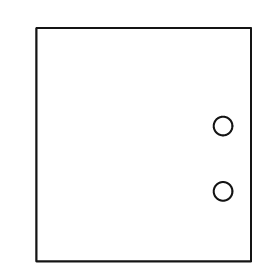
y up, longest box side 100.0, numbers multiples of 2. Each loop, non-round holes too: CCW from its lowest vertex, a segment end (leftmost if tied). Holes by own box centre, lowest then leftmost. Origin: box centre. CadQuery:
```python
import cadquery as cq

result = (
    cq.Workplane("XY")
    .moveTo(-46.0, -50.0)
    .lineTo(46.0, -50.0)
    .lineTo(46.0, 50.0)
    .lineTo(-46.0, 50.0)
    .close()
    .moveTo(34.0, -20.0)
    .circle(4.0)
    .moveTo(34.0, 8.0)
    .circle(4.0)
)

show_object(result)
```